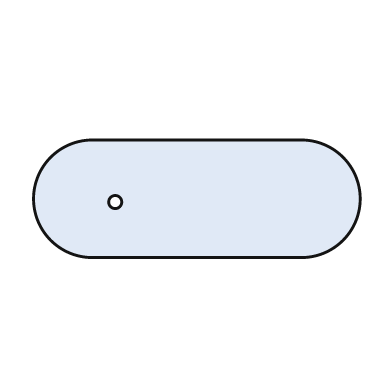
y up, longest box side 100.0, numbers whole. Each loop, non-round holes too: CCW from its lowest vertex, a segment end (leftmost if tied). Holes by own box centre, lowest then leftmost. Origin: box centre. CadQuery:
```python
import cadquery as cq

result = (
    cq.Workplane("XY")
    .moveTo(-32.0, -18.0)
    .lineTo(32.0, -18.0)
    .threePointArc((50.0, 0.0), (32.0, 18.0))
    .lineTo(-32.0, 18.0)
    .threePointArc((-50.0, 0.0), (-32.0, -18.0))
    .close()
    .moveTo(-25.0, -1.0)
    .circle(2.0)
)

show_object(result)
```